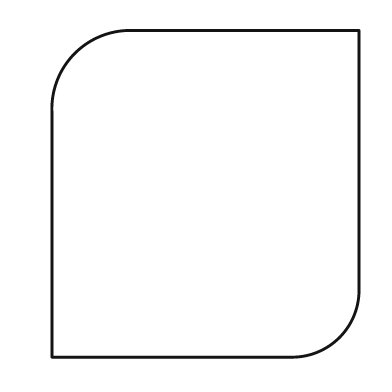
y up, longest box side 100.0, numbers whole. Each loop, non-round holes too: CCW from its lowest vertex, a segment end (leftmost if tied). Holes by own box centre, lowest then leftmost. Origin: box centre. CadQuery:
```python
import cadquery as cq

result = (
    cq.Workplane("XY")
    .moveTo(-47.0, -50.0)
    .lineTo(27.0, -50.0)
    .threePointArc((41.0, -44.0), (47.0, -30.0))
    .lineTo(47.0, 50.0)
    .lineTo(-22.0, 50.0)
    .threePointArc((-40.0, 43.0), (-47.0, 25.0))
    .close()
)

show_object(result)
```